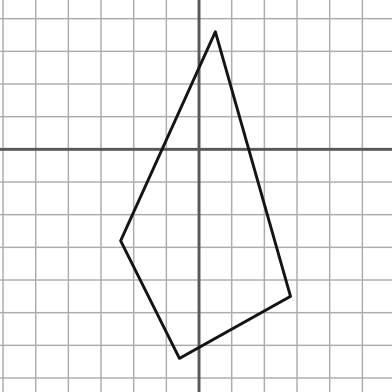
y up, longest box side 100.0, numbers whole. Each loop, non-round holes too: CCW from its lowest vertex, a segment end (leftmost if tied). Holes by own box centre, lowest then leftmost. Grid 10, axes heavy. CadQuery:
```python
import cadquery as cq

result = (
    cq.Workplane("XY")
    .moveTo(-6.0, -64.0)
    .lineTo(28.0, -45.0)
    .lineTo(5.0, 36.0)
    .lineTo(-24.0, -28.0)
    .close()
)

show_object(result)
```